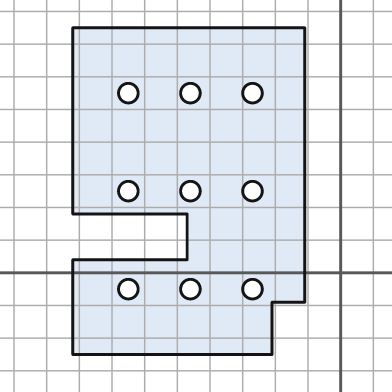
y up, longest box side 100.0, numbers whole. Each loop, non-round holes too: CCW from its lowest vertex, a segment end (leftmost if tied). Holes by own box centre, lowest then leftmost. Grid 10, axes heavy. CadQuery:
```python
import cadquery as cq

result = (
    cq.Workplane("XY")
    .moveTo(-82.0, -25.0)
    .lineTo(-21.0, -25.0)
    .lineTo(-21.0, -9.0)
    .lineTo(-11.0, -9.0)
    .lineTo(-11.0, 75.0)
    .lineTo(-82.0, 75.0)
    .lineTo(-82.0, 18.0)
    .lineTo(-47.0, 18.0)
    .lineTo(-47.0, 4.0)
    .lineTo(-82.0, 4.0)
    .close()
    .moveTo(-65.0, -5.0)
    .circle(3.0)
    .moveTo(-46.0, -5.0)
    .circle(3.0)
    .moveTo(-27.0, -5.0)
    .circle(3.0)
    .moveTo(-65.0, 25.0)
    .circle(3.0)
    .moveTo(-46.0, 25.0)
    .circle(3.0)
    .moveTo(-27.0, 25.0)
    .circle(3.0)
    .moveTo(-65.0, 55.0)
    .circle(3.0)
    .moveTo(-46.0, 55.0)
    .circle(3.0)
    .moveTo(-27.0, 55.0)
    .circle(3.0)
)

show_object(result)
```